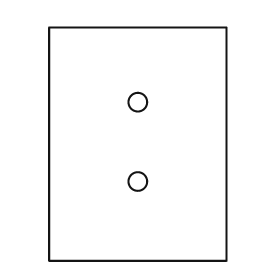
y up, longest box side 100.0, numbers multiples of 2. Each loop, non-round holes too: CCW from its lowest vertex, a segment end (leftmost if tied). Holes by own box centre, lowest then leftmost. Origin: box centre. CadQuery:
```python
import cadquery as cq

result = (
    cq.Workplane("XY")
    .moveTo(-38.0, -50.0)
    .lineTo(38.0, -50.0)
    .lineTo(38.0, 50.0)
    .lineTo(-38.0, 50.0)
    .close()
    .moveTo(0.0, -16.0)
    .circle(4.0)
    .moveTo(0.0, 18.0)
    .circle(4.0)
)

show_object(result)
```